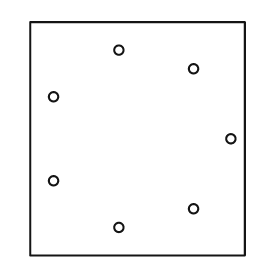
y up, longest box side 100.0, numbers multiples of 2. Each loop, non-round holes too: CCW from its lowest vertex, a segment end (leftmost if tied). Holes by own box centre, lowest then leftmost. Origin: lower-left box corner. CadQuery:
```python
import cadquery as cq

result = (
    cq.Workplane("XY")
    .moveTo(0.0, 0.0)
    .lineTo(92.0, 0.0)
    .lineTo(92.0, 100.0)
    .lineTo(0.0, 100.0)
    .close()
    .moveTo(38.0, 12.0)
    .circle(2.0)
    .moveTo(70.0, 20.0)
    .circle(2.0)
    .moveTo(10.0, 32.0)
    .circle(2.0)
    .moveTo(86.0, 50.0)
    .circle(2.0)
    .moveTo(10.0, 68.0)
    .circle(2.0)
    .moveTo(70.0, 80.0)
    .circle(2.0)
    .moveTo(38.0, 88.0)
    .circle(2.0)
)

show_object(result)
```